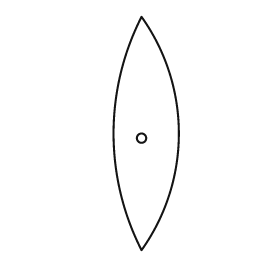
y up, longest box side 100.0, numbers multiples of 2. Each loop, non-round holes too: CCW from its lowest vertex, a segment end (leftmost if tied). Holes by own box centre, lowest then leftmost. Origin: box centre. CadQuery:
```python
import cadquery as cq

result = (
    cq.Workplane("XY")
    .moveTo(-2.0, -50.0)
    .threePointArc((14.0, 0.0), (-2.0, 50.0))
    .threePointArc((-14.0, 0.0), (-2.0, -50.0))
    .close()
    .moveTo(-2.0, -2.0)
    .circle(2.0)
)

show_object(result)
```